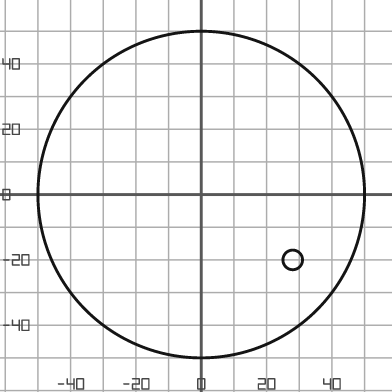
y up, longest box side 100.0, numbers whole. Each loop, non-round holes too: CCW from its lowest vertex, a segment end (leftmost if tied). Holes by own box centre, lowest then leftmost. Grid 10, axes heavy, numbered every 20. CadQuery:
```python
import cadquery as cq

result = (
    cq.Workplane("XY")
    .moveTo(0.0, 0.0)
    .circle(50.0)
    .moveTo(28.0, -20.0)
    .circle(3.0)
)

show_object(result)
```